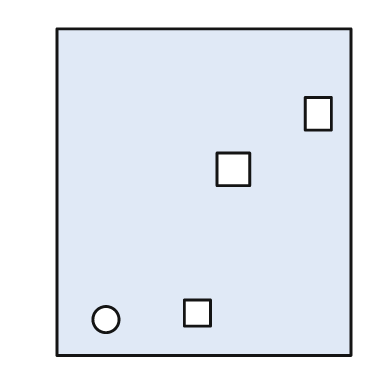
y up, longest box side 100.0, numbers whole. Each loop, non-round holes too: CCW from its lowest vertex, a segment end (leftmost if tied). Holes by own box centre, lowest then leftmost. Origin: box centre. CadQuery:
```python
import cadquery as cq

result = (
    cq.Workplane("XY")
    .moveTo(-45.0, -50.0)
    .lineTo(45.0, -50.0)
    .lineTo(45.0, 50.0)
    .lineTo(-45.0, 50.0)
    .close()
    .moveTo(-30.0, -39.0)
    .circle(4.0)
    .moveTo(-6.0, -41.0)
    .lineTo(2.0, -41.0)
    .lineTo(2.0, -33.0)
    .lineTo(-6.0, -33.0)
    .close()
    .moveTo(4.0, 2.0)
    .lineTo(14.0, 2.0)
    .lineTo(14.0, 12.0)
    .lineTo(4.0, 12.0)
    .close()
    .moveTo(31.0, 19.0)
    .lineTo(39.0, 19.0)
    .lineTo(39.0, 29.0)
    .lineTo(31.0, 29.0)
    .close()
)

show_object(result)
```